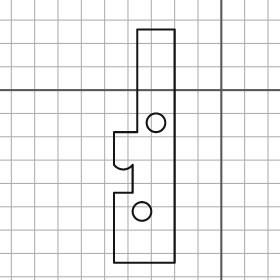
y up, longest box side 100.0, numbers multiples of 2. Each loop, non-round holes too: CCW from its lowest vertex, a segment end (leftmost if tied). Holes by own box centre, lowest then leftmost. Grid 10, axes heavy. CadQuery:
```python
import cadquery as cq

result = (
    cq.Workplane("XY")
    .moveTo(-46.0, -74.0)
    .lineTo(-20.0, -74.0)
    .lineTo(-20.0, 26.0)
    .lineTo(-36.0, 26.0)
    .lineTo(-36.0, -18.0)
    .lineTo(-46.0, -18.0)
    .lineTo(-46.0, -32.0)
    .threePointArc((-42.0, -34.0), (-38.0, -32.0))
    .lineTo(-38.0, -44.0)
    .lineTo(-46.0, -44.0)
    .close()
    .moveTo(-34.0, -52.0)
    .circle(4.0)
    .moveTo(-28.0, -14.0)
    .circle(4.0)
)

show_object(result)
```